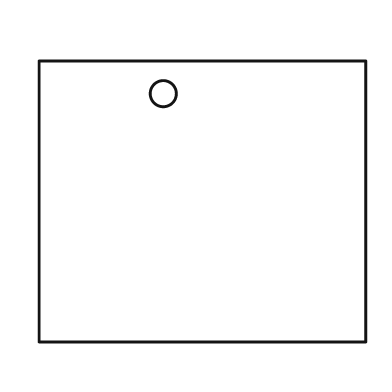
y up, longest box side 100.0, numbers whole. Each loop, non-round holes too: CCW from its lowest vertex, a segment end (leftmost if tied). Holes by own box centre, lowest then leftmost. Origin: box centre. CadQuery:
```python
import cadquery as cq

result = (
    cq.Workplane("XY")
    .moveTo(-50.0, -43.0)
    .lineTo(50.0, -43.0)
    .lineTo(50.0, 43.0)
    .lineTo(-50.0, 43.0)
    .close()
    .moveTo(-12.0, 33.0)
    .circle(4.0)
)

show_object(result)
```